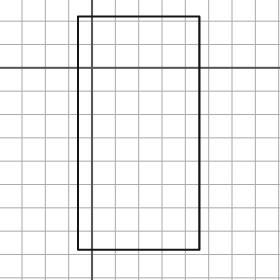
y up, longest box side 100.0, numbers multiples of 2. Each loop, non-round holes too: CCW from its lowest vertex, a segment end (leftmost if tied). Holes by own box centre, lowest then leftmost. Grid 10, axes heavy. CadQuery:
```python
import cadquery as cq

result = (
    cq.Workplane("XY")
    .moveTo(-6.0, -78.0)
    .lineTo(46.0, -78.0)
    .lineTo(46.0, 22.0)
    .lineTo(-6.0, 22.0)
    .close()
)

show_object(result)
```